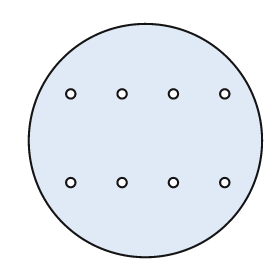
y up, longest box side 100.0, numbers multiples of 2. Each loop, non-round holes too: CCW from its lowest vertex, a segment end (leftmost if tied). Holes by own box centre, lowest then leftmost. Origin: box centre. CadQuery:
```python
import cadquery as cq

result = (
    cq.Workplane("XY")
    .moveTo(0.0, 0.0)
    .circle(50.0)
    .moveTo(-32.0, -18.0)
    .circle(2.0)
    .moveTo(-10.0, -18.0)
    .circle(2.0)
    .moveTo(12.0, -18.0)
    .circle(2.0)
    .moveTo(34.0, -18.0)
    .circle(2.0)
    .moveTo(-32.0, 20.0)
    .circle(2.0)
    .moveTo(-10.0, 20.0)
    .circle(2.0)
    .moveTo(12.0, 20.0)
    .circle(2.0)
    .moveTo(34.0, 20.0)
    .circle(2.0)
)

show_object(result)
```